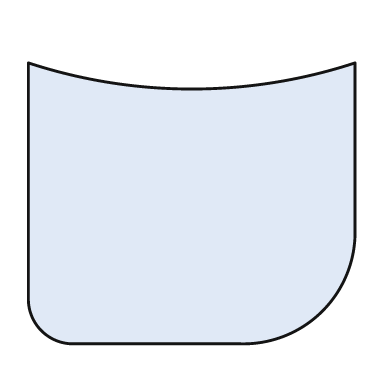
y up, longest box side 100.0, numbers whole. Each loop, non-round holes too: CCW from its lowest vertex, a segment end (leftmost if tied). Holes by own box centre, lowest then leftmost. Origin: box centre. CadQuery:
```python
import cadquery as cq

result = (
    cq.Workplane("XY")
    .moveTo(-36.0, -43.0)
    .lineTo(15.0, -43.0)
    .threePointArc((40.0, -33.0), (50.0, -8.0))
    .lineTo(50.0, 43.0)
    .threePointArc((0.0, 35.0), (-50.0, 43.0))
    .lineTo(-50.0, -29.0)
    .threePointArc((-46.0, -39.0), (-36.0, -43.0))
    .close()
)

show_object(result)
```